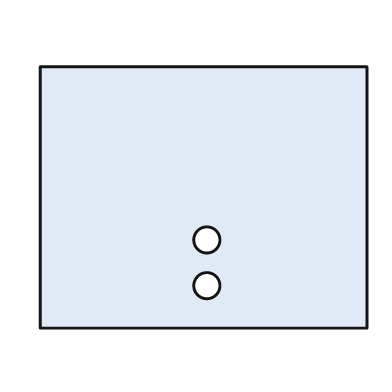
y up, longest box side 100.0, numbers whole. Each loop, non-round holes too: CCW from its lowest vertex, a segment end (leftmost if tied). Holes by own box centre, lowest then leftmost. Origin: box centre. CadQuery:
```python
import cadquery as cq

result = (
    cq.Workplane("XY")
    .moveTo(-50.0, -40.0)
    .lineTo(50.0, -40.0)
    .lineTo(50.0, 40.0)
    .lineTo(-50.0, 40.0)
    .close()
    .moveTo(1.0, -27.0)
    .circle(4.0)
    .moveTo(1.0, -13.0)
    .circle(4.0)
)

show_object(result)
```